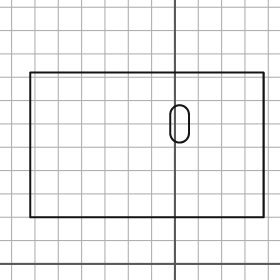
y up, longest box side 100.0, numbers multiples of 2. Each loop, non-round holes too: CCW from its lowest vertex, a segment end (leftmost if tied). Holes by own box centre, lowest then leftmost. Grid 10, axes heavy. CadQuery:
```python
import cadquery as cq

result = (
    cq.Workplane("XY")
    .moveTo(-62.0, 20.0)
    .lineTo(38.0, 20.0)
    .lineTo(38.0, 82.0)
    .lineTo(-62.0, 82.0)
    .close()
    .moveTo(-2.0, 56.0)
    .threePointArc((2.0, 52.0), (6.0, 56.0))
    .lineTo(6.0, 64.0)
    .threePointArc((2.0, 68.0), (-2.0, 64.0))
    .close()
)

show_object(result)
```